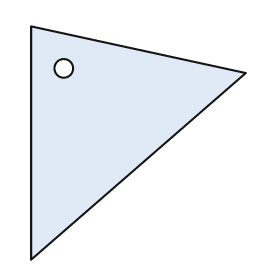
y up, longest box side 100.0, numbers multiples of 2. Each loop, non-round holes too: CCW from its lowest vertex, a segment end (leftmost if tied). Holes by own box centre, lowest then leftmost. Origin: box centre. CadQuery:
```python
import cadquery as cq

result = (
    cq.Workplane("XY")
    .moveTo(-46.0, -50.0)
    .lineTo(46.0, 30.0)
    .lineTo(-46.0, 50.0)
    .close()
    .moveTo(-32.0, 32.0)
    .circle(4.0)
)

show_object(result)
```